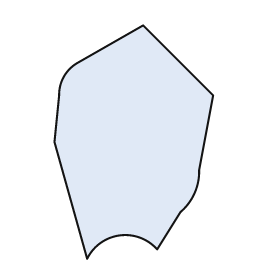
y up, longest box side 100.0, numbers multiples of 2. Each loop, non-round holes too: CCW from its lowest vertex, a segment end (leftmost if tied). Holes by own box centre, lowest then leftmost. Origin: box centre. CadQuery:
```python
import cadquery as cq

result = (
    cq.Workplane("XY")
    .moveTo(-20.0, -50.0)
    .threePointArc((-6.0, -40.0), (10.0, -46.0))
    .lineTo(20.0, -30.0)
    .threePointArc((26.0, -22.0), (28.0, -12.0))
    .lineTo(34.0, 20.0)
    .lineTo(4.0, 50.0)
    .lineTo(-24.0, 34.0)
    .threePointArc((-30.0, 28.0), (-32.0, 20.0))
    .lineTo(-34.0, 0.0)
    .close()
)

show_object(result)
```